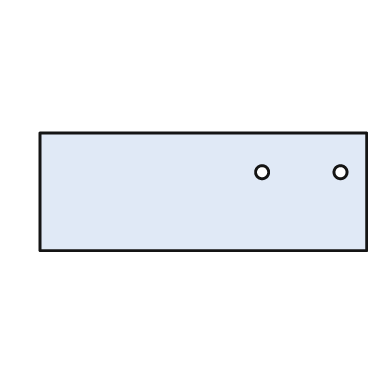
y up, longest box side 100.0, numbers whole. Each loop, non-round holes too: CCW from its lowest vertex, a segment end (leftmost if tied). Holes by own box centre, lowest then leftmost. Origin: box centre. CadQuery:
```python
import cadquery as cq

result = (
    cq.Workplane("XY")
    .moveTo(-50.0, -18.0)
    .lineTo(50.0, -18.0)
    .lineTo(50.0, 18.0)
    .lineTo(-50.0, 18.0)
    .close()
    .moveTo(18.0, 6.0)
    .circle(2.0)
    .moveTo(42.0, 6.0)
    .circle(2.0)
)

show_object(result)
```